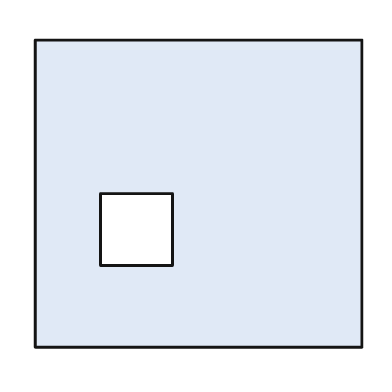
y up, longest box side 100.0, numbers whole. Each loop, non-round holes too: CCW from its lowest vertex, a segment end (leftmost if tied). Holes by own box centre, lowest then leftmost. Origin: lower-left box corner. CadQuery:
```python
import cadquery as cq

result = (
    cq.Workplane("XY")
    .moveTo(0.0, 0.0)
    .lineTo(100.0, 0.0)
    .lineTo(100.0, 94.0)
    .lineTo(0.0, 94.0)
    .close()
    .moveTo(20.0, 25.0)
    .lineTo(42.0, 25.0)
    .lineTo(42.0, 47.0)
    .lineTo(20.0, 47.0)
    .close()
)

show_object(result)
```